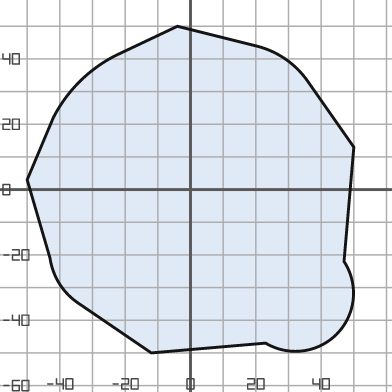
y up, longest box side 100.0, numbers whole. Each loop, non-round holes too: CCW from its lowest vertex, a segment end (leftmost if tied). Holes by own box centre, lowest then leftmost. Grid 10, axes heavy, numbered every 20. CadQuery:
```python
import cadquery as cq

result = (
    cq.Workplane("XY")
    .moveTo(-12.0, -50.0)
    .lineTo(23.0, -47.0)
    .threePointArc((45.0, -44.0), (47.0, -22.0))
    .lineTo(50.0, 13.0)
    .lineTo(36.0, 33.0)
    .threePointArc((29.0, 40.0), (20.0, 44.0))
    .lineTo(-4.0, 50.0)
    .lineTo(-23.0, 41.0)
    .threePointArc((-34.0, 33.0), (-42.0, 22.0))
    .lineTo(-50.0, 3.0)
    .lineTo(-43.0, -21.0)
    .threePointArc((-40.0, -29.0), (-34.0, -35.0))
    .close()
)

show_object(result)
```